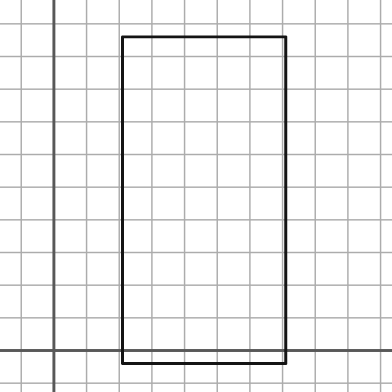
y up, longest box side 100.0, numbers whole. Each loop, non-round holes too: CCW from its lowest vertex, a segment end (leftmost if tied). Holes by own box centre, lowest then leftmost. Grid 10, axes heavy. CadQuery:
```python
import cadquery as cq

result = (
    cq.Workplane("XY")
    .moveTo(21.0, -4.0)
    .lineTo(71.0, -4.0)
    .lineTo(71.0, 96.0)
    .lineTo(21.0, 96.0)
    .close()
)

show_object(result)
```